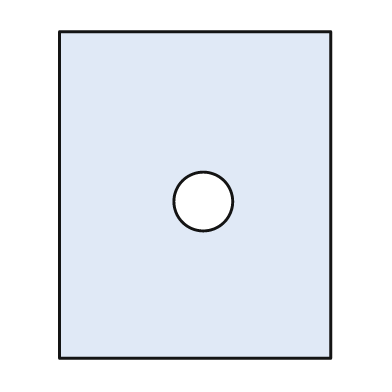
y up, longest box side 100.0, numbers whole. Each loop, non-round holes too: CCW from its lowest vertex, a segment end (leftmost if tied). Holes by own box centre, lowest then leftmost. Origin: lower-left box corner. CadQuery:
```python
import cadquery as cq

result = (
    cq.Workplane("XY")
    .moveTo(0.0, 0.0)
    .lineTo(83.0, 0.0)
    .lineTo(83.0, 100.0)
    .lineTo(0.0, 100.0)
    .close()
    .moveTo(44.0, 48.0)
    .circle(9.0)
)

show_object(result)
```